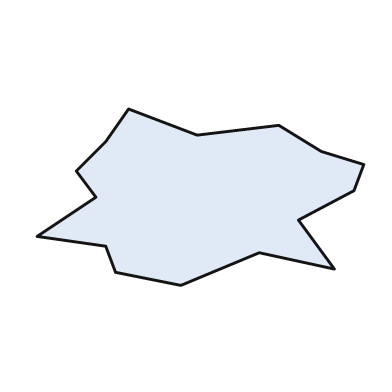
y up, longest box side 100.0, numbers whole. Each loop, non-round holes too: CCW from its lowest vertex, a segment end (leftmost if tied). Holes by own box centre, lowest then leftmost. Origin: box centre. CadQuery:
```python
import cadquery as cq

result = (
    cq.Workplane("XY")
    .moveTo(-6.0, -27.0)
    .lineTo(18.0, -17.0)
    .lineTo(41.0, -22.0)
    .lineTo(30.0, -7.0)
    .lineTo(47.0, 2.0)
    .lineTo(50.0, 10.0)
    .lineTo(37.0, 14.0)
    .lineTo(24.0, 22.0)
    .lineTo(-1.0, 19.0)
    .lineTo(-22.0, 27.0)
    .lineTo(-29.0, 17.0)
    .lineTo(-38.0, 8.0)
    .lineTo(-32.0, 0.0)
    .lineTo(-50.0, -12.0)
    .lineTo(-29.0, -15.0)
    .lineTo(-26.0, -23.0)
    .close()
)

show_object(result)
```